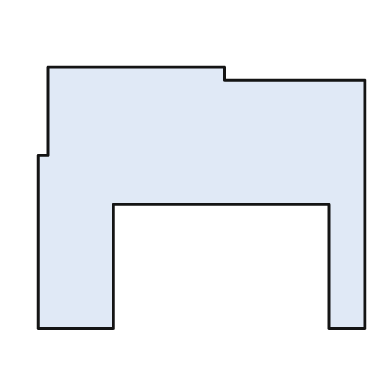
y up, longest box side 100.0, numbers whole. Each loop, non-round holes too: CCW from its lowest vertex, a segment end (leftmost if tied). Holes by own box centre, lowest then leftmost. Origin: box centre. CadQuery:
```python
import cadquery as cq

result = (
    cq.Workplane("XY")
    .moveTo(-50.0, -40.0)
    .lineTo(-27.0, -40.0)
    .lineTo(-27.0, -2.0)
    .lineTo(39.0, -2.0)
    .lineTo(39.0, -40.0)
    .lineTo(50.0, -40.0)
    .lineTo(50.0, 36.0)
    .lineTo(7.0, 36.0)
    .lineTo(7.0, 40.0)
    .lineTo(-47.0, 40.0)
    .lineTo(-47.0, 13.0)
    .lineTo(-50.0, 13.0)
    .close()
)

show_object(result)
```